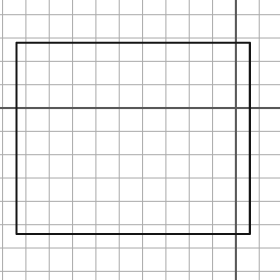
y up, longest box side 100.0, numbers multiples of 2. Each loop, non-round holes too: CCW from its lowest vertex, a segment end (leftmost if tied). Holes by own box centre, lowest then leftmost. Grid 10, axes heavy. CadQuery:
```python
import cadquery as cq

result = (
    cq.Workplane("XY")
    .moveTo(-94.0, -54.0)
    .lineTo(6.0, -54.0)
    .lineTo(6.0, 28.0)
    .lineTo(-94.0, 28.0)
    .close()
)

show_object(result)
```